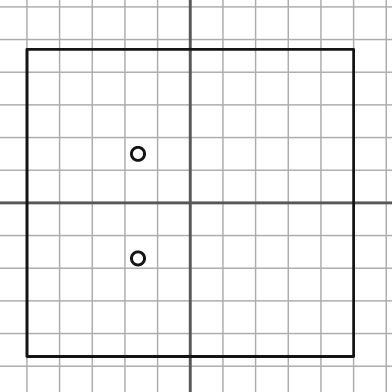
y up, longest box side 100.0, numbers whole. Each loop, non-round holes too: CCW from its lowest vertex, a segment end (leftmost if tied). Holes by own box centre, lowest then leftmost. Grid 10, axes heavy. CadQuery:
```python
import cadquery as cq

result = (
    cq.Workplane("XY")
    .moveTo(-50.0, -47.0)
    .lineTo(50.0, -47.0)
    .lineTo(50.0, 47.0)
    .lineTo(-50.0, 47.0)
    .close()
    .moveTo(-16.0, -17.0)
    .circle(2.0)
    .moveTo(-16.0, 15.0)
    .circle(2.0)
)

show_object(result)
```